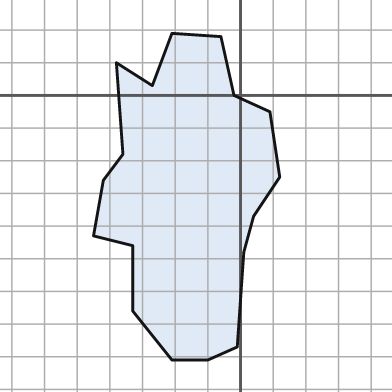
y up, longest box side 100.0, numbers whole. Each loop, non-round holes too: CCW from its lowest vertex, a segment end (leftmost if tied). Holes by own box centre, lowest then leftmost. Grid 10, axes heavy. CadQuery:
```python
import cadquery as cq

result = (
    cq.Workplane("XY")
    .moveTo(-21.0, -81.0)
    .lineTo(-10.0, -81.0)
    .lineTo(-1.0, -77.0)
    .lineTo(1.0, -48.0)
    .lineTo(4.0, -37.0)
    .lineTo(12.0, -25.0)
    .lineTo(9.0, -5.0)
    .lineTo(-2.0, 0.0)
    .lineTo(-6.0, 18.0)
    .lineTo(-21.0, 19.0)
    .lineTo(-27.0, 3.0)
    .lineTo(-38.0, 10.0)
    .lineTo(-36.0, -18.0)
    .lineTo(-42.0, -26.0)
    .lineTo(-45.0, -43.0)
    .lineTo(-33.0, -46.0)
    .lineTo(-33.0, -66.0)
    .close()
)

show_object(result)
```